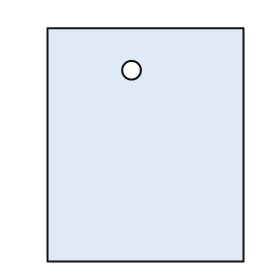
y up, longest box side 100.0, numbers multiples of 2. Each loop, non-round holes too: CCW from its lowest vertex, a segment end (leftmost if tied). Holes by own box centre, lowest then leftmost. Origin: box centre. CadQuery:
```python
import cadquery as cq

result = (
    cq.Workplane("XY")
    .moveTo(-42.0, -50.0)
    .lineTo(42.0, -50.0)
    .lineTo(42.0, 50.0)
    .lineTo(-42.0, 50.0)
    .close()
    .moveTo(-6.0, 32.0)
    .circle(4.0)
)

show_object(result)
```